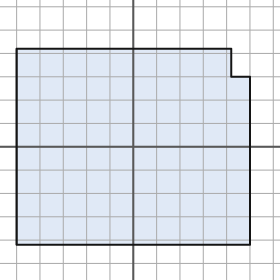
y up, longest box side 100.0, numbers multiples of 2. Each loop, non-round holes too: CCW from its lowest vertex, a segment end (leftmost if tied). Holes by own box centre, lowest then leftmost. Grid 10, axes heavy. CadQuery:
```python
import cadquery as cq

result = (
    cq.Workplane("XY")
    .moveTo(-50.0, -42.0)
    .lineTo(50.0, -42.0)
    .lineTo(50.0, 30.0)
    .lineTo(42.0, 30.0)
    .lineTo(42.0, 42.0)
    .lineTo(-50.0, 42.0)
    .close()
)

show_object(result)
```